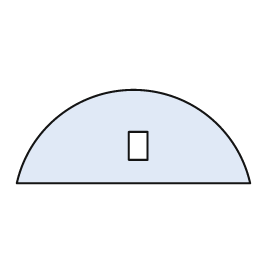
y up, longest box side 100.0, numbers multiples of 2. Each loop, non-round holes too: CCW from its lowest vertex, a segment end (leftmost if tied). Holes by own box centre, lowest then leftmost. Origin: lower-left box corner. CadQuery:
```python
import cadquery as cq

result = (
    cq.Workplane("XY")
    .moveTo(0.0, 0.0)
    .lineTo(100.0, 0.0)
    .threePointArc((50.0, 40.0), (0.0, 0.0))
    .close()
    .moveTo(48.0, 10.0)
    .lineTo(56.0, 10.0)
    .lineTo(56.0, 22.0)
    .lineTo(48.0, 22.0)
    .close()
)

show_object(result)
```